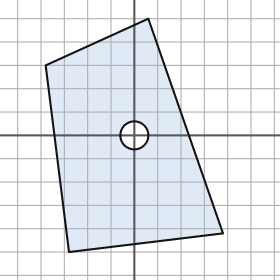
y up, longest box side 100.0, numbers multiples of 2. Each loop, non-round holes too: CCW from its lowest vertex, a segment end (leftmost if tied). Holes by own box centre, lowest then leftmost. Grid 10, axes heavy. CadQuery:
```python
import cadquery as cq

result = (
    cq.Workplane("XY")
    .moveTo(-28.0, -50.0)
    .lineTo(38.0, -42.0)
    .lineTo(6.0, 50.0)
    .lineTo(-38.0, 30.0)
    .close()
    .moveTo(0.0, 0.0)
    .circle(6.0)
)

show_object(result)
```